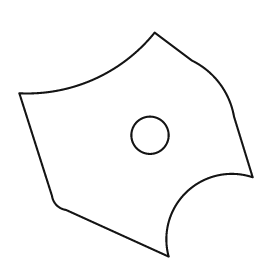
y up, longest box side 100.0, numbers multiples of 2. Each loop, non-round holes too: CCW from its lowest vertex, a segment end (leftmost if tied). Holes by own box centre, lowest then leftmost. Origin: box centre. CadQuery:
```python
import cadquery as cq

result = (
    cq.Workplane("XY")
    .moveTo(14.0, -48.0)
    .threePointArc((22.0, -20.0), (50.0, -14.0))
    .lineTo(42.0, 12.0)
    .threePointArc((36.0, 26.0), (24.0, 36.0))
    .lineTo(8.0, 48.0)
    .threePointArc((-18.0, 28.0), (-50.0, 22.0))
    .lineTo(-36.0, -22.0)
    .threePointArc((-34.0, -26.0), (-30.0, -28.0))
    .close()
    .moveTo(6.0, 4.0)
    .circle(8.0)
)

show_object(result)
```